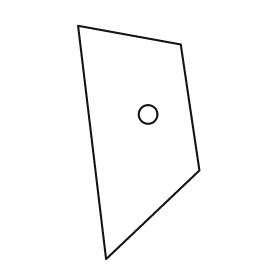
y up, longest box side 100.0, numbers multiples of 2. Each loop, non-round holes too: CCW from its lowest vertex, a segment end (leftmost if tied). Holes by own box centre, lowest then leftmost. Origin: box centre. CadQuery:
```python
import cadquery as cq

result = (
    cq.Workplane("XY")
    .moveTo(-14.0, -50.0)
    .lineTo(26.0, -12.0)
    .lineTo(18.0, 42.0)
    .lineTo(-26.0, 50.0)
    .close()
    .moveTo(4.0, 12.0)
    .circle(4.0)
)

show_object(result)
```